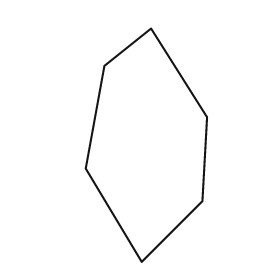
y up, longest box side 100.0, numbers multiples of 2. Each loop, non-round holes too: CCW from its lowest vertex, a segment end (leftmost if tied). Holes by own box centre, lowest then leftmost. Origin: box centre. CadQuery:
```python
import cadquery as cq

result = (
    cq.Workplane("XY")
    .moveTo(-2.0, -50.0)
    .lineTo(24.0, -24.0)
    .lineTo(26.0, 12.0)
    .lineTo(2.0, 50.0)
    .lineTo(-18.0, 34.0)
    .lineTo(-26.0, -10.0)
    .close()
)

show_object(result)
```